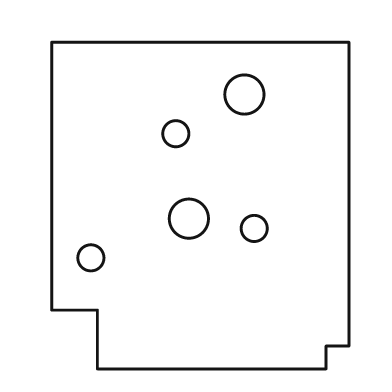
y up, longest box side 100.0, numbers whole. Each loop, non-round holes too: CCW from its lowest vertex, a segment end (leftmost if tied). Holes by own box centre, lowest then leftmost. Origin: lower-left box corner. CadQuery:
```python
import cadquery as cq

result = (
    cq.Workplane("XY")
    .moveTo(14.0, 0.0)
    .lineTo(84.0, 0.0)
    .lineTo(84.0, 7.0)
    .lineTo(91.0, 7.0)
    .lineTo(91.0, 100.0)
    .lineTo(0.0, 100.0)
    .lineTo(0.0, 18.0)
    .lineTo(14.0, 18.0)
    .close()
    .moveTo(12.0, 34.0)
    .circle(4.0)
    .moveTo(62.0, 43.0)
    .circle(4.0)
    .moveTo(42.0, 46.0)
    .circle(6.0)
    .moveTo(38.0, 72.0)
    .circle(4.0)
    .moveTo(59.0, 84.0)
    .circle(6.0)
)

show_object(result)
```